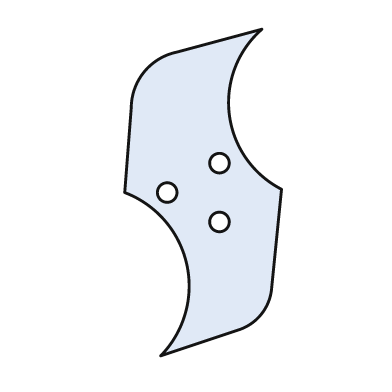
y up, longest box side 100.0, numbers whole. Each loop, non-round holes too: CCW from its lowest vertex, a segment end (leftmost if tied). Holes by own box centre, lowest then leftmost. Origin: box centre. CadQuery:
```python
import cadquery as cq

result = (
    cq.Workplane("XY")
    .moveTo(-13.0, -50.0)
    .lineTo(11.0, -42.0)
    .threePointArc((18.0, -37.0), (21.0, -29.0))
    .lineTo(24.0, 1.0)
    .threePointArc((8.0, 24.0), (18.0, 50.0))
    .lineTo(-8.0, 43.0)
    .threePointArc((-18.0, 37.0), (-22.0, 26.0))
    .lineTo(-24.0, 0.0)
    .threePointArc((-5.0, -22.0), (-13.0, -50.0))
    .close()
    .moveTo(5.0, -9.0)
    .circle(3.0)
    .moveTo(-11.0, 0.0)
    .circle(3.0)
    .moveTo(5.0, 9.0)
    .circle(3.0)
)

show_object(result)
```